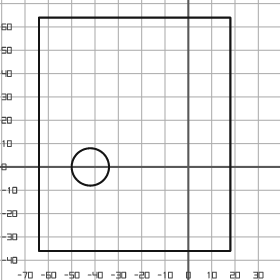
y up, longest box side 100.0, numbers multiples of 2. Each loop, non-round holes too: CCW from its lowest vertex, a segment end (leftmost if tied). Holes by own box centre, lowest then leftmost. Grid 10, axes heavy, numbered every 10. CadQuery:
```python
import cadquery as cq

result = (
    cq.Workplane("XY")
    .moveTo(-64.0, -36.0)
    .lineTo(18.0, -36.0)
    .lineTo(18.0, 64.0)
    .lineTo(-64.0, 64.0)
    .close()
    .moveTo(-42.0, 0.0)
    .circle(8.0)
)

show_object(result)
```